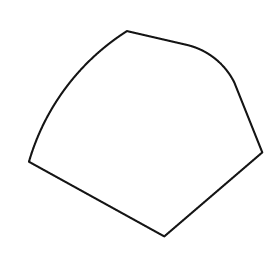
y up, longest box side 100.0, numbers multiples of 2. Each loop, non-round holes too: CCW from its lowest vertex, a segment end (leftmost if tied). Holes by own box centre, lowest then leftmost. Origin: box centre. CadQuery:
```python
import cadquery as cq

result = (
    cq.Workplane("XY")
    .moveTo(8.0, -44.0)
    .lineTo(50.0, -8.0)
    .lineTo(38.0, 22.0)
    .threePointArc((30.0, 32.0), (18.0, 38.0))
    .lineTo(-8.0, 44.0)
    .threePointArc((-34.0, 20.0), (-50.0, -12.0))
    .close()
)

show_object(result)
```